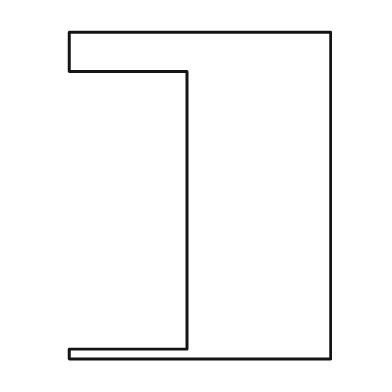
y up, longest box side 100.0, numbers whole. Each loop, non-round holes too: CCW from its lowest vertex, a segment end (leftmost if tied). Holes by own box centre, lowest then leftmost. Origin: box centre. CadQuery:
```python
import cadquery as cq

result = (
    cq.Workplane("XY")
    .moveTo(-40.0, -50.0)
    .lineTo(40.0, -50.0)
    .lineTo(40.0, 50.0)
    .lineTo(-40.0, 50.0)
    .lineTo(-40.0, 38.0)
    .lineTo(-4.0, 38.0)
    .lineTo(-4.0, -47.0)
    .lineTo(-40.0, -47.0)
    .close()
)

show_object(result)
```